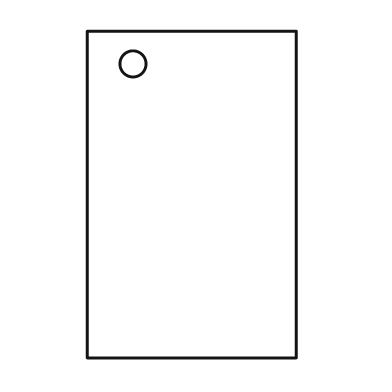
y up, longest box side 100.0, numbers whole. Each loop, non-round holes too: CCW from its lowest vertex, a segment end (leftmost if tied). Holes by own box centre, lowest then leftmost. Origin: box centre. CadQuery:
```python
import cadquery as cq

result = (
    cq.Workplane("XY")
    .moveTo(-32.0, -50.0)
    .lineTo(32.0, -50.0)
    .lineTo(32.0, 50.0)
    .lineTo(-32.0, 50.0)
    .close()
    .moveTo(-18.0, 40.0)
    .circle(4.0)
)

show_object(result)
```